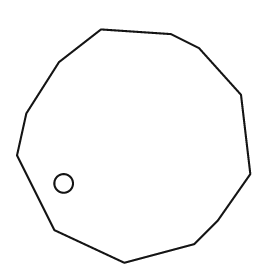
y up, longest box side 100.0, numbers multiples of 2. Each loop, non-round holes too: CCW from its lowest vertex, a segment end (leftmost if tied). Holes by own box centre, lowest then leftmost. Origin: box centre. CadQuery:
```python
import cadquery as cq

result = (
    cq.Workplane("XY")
    .moveTo(-4.0, -50.0)
    .lineTo(26.0, -42.0)
    .lineTo(36.0, -32.0)
    .lineTo(50.0, -12.0)
    .lineTo(46.0, 22.0)
    .lineTo(28.0, 42.0)
    .lineTo(16.0, 48.0)
    .lineTo(-14.0, 50.0)
    .lineTo(-32.0, 36.0)
    .lineTo(-46.0, 14.0)
    .lineTo(-50.0, -4.0)
    .lineTo(-34.0, -36.0)
    .close()
    .moveTo(-30.0, -16.0)
    .circle(4.0)
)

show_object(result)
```